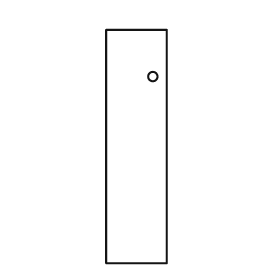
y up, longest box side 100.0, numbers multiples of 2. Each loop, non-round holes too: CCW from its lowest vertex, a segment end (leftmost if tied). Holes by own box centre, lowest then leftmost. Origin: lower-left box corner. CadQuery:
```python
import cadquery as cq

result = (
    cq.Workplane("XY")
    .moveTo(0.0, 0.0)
    .lineTo(26.0, 0.0)
    .lineTo(26.0, 100.0)
    .lineTo(0.0, 100.0)
    .close()
    .moveTo(20.0, 80.0)
    .circle(2.0)
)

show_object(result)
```